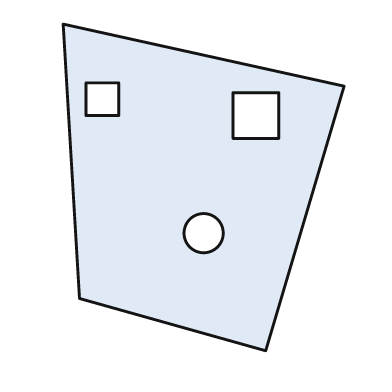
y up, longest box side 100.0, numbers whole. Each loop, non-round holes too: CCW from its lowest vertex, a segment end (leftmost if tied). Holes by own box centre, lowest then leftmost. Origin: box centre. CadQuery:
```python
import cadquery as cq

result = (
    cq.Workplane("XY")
    .moveTo(19.0, -50.0)
    .lineTo(43.0, 31.0)
    .lineTo(-43.0, 50.0)
    .lineTo(-38.0, -34.0)
    .close()
    .moveTo(0.0, -14.0)
    .circle(6.0)
    .moveTo(9.0, 15.0)
    .lineTo(23.0, 15.0)
    .lineTo(23.0, 29.0)
    .lineTo(9.0, 29.0)
    .close()
    .moveTo(-36.0, 22.0)
    .lineTo(-26.0, 22.0)
    .lineTo(-26.0, 32.0)
    .lineTo(-36.0, 32.0)
    .close()
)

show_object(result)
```